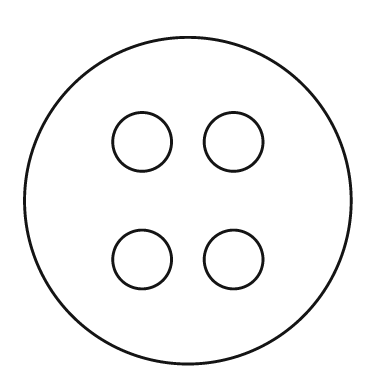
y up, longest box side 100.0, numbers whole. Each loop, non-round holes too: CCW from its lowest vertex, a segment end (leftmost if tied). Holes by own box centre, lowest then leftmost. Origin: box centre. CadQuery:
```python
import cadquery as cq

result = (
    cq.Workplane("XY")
    .moveTo(0.0, 0.0)
    .circle(50.0)
    .moveTo(-14.0, -18.0)
    .circle(9.0)
    .moveTo(14.0, -18.0)
    .circle(9.0)
    .moveTo(-14.0, 18.0)
    .circle(9.0)
    .moveTo(14.0, 18.0)
    .circle(9.0)
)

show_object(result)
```